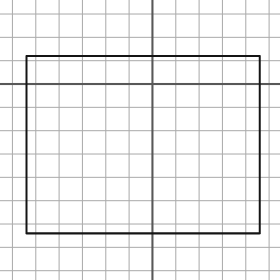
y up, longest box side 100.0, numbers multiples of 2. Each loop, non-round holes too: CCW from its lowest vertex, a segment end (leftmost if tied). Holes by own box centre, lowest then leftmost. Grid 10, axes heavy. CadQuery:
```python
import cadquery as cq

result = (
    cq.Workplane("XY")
    .moveTo(-54.0, -64.0)
    .lineTo(46.0, -64.0)
    .lineTo(46.0, 12.0)
    .lineTo(-54.0, 12.0)
    .close()
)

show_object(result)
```